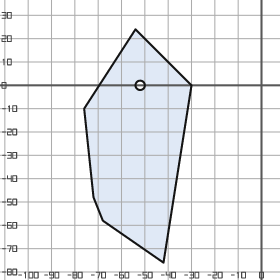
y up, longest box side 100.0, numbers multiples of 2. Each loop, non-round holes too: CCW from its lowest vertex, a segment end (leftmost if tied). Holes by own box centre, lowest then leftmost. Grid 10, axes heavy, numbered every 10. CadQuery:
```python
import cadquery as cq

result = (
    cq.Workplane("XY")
    .moveTo(-42.0, -76.0)
    .lineTo(-30.0, 0.0)
    .lineTo(-54.0, 24.0)
    .lineTo(-76.0, -10.0)
    .lineTo(-72.0, -48.0)
    .lineTo(-68.0, -58.0)
    .close()
    .moveTo(-52.0, 0.0)
    .circle(2.0)
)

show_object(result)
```